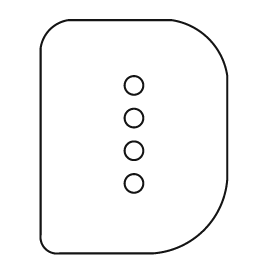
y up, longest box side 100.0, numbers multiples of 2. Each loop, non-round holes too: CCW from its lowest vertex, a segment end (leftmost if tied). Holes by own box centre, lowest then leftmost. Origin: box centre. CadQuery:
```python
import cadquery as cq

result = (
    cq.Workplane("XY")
    .moveTo(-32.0, -50.0)
    .lineTo(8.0, -50.0)
    .threePointArc((30.0, -40.0), (40.0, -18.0))
    .lineTo(40.0, 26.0)
    .threePointArc((32.0, 42.0), (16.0, 50.0))
    .lineTo(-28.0, 50.0)
    .threePointArc((-36.0, 46.0), (-40.0, 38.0))
    .lineTo(-40.0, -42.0)
    .threePointArc((-38.0, -48.0), (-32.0, -50.0))
    .close()
    .moveTo(0.0, -20.0)
    .circle(4.0)
    .moveTo(0.0, -6.0)
    .circle(4.0)
    .moveTo(0.0, 8.0)
    .circle(4.0)
    .moveTo(0.0, 22.0)
    .circle(4.0)
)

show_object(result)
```